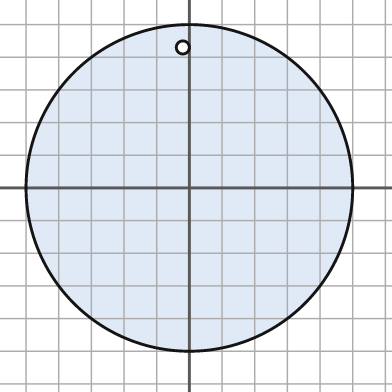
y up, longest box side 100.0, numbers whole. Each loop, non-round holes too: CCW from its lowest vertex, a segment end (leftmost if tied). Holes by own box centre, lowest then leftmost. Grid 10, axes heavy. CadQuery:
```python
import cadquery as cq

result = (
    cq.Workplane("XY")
    .moveTo(0.0, 0.0)
    .circle(50.0)
    .moveTo(-2.0, 43.0)
    .circle(2.0)
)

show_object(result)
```